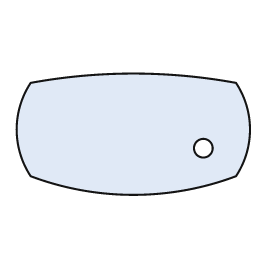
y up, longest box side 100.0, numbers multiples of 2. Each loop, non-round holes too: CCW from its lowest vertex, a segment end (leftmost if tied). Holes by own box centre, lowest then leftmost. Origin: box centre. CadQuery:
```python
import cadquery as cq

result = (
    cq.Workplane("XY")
    .moveTo(-44.0, -18.0)
    .threePointArc((0.0, -26.0), (44.0, -18.0))
    .threePointArc((50.0, 2.0), (44.0, 22.0))
    .threePointArc((0.0, 26.0), (-44.0, 22.0))
    .threePointArc((-50.0, 2.0), (-44.0, -18.0))
    .close()
    .moveTo(30.0, -6.0)
    .circle(4.0)
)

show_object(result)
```